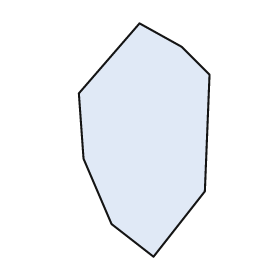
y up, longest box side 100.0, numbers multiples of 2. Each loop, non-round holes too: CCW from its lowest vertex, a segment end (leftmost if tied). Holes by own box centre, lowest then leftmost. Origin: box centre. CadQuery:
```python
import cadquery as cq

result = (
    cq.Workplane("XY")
    .moveTo(4.0, -50.0)
    .lineTo(26.0, -22.0)
    .lineTo(28.0, 28.0)
    .lineTo(16.0, 40.0)
    .lineTo(-2.0, 50.0)
    .lineTo(-28.0, 20.0)
    .lineTo(-26.0, -8.0)
    .lineTo(-14.0, -36.0)
    .close()
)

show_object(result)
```